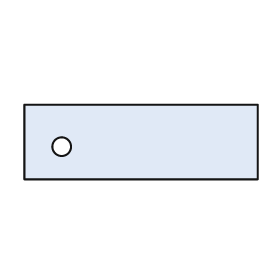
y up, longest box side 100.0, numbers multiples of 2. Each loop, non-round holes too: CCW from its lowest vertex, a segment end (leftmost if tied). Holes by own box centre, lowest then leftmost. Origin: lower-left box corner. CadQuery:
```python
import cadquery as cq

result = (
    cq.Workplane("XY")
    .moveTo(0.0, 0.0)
    .lineTo(100.0, 0.0)
    .lineTo(100.0, 32.0)
    .lineTo(0.0, 32.0)
    .close()
    .moveTo(16.0, 14.0)
    .circle(4.0)
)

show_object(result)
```